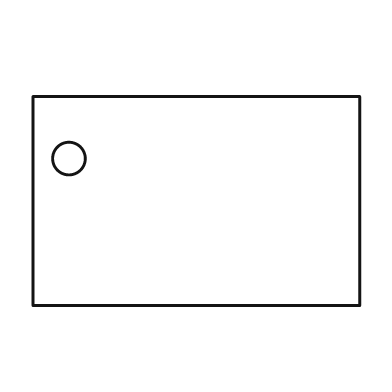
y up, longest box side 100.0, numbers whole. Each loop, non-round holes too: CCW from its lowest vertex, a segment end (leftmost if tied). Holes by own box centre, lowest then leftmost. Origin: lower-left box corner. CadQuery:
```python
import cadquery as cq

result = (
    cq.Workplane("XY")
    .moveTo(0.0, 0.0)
    .lineTo(100.0, 0.0)
    .lineTo(100.0, 64.0)
    .lineTo(0.0, 64.0)
    .close()
    .moveTo(11.0, 45.0)
    .circle(5.0)
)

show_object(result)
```